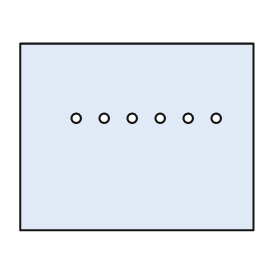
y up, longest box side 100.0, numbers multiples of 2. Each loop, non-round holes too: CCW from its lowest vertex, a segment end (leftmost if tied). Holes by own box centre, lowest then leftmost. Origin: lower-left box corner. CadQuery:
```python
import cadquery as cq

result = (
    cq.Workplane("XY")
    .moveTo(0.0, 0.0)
    .lineTo(100.0, 0.0)
    .lineTo(100.0, 80.0)
    .lineTo(0.0, 80.0)
    .close()
    .moveTo(24.0, 48.0)
    .circle(2.0)
    .moveTo(36.0, 48.0)
    .circle(2.0)
    .moveTo(48.0, 48.0)
    .circle(2.0)
    .moveTo(60.0, 48.0)
    .circle(2.0)
    .moveTo(72.0, 48.0)
    .circle(2.0)
    .moveTo(84.0, 48.0)
    .circle(2.0)
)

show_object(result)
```